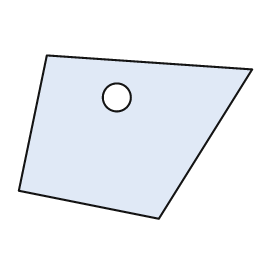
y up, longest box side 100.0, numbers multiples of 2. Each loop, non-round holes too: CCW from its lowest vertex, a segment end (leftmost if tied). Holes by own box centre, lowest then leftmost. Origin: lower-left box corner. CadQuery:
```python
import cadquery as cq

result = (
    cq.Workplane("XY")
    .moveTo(60.0, 0.0)
    .lineTo(100.0, 64.0)
    .lineTo(12.0, 70.0)
    .lineTo(0.0, 12.0)
    .close()
    .moveTo(42.0, 52.0)
    .circle(6.0)
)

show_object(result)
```